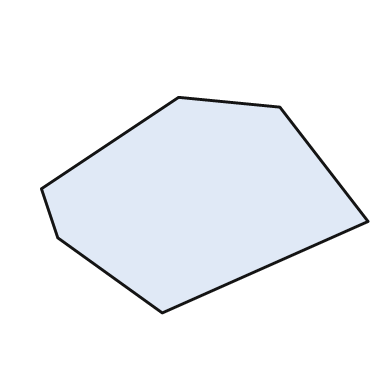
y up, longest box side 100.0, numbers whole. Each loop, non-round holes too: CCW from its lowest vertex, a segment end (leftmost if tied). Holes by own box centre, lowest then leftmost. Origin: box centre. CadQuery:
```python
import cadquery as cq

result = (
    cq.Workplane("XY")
    .moveTo(-13.0, -33.0)
    .lineTo(50.0, -5.0)
    .lineTo(23.0, 30.0)
    .lineTo(-8.0, 33.0)
    .lineTo(-50.0, 5.0)
    .lineTo(-45.0, -10.0)
    .close()
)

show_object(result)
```